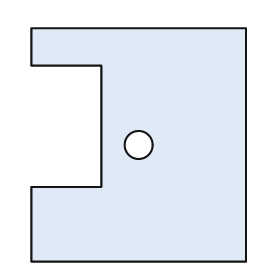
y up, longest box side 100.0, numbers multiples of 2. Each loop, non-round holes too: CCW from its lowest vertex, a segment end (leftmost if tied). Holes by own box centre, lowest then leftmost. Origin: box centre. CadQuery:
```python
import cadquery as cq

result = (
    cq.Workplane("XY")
    .moveTo(-46.0, -50.0)
    .lineTo(46.0, -50.0)
    .lineTo(46.0, 50.0)
    .lineTo(-46.0, 50.0)
    .lineTo(-46.0, 34.0)
    .lineTo(-16.0, 34.0)
    .lineTo(-16.0, -18.0)
    .lineTo(-46.0, -18.0)
    .close()
    .moveTo(0.0, 0.0)
    .circle(6.0)
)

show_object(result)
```